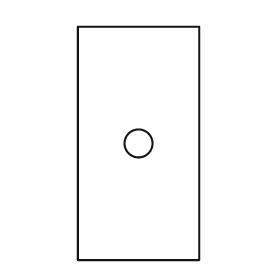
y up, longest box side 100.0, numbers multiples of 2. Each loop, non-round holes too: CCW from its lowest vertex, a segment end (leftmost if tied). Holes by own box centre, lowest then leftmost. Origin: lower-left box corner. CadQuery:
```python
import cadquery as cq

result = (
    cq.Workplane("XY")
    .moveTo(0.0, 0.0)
    .lineTo(52.0, 0.0)
    .lineTo(52.0, 100.0)
    .lineTo(0.0, 100.0)
    .close()
    .moveTo(26.0, 50.0)
    .circle(6.0)
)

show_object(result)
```